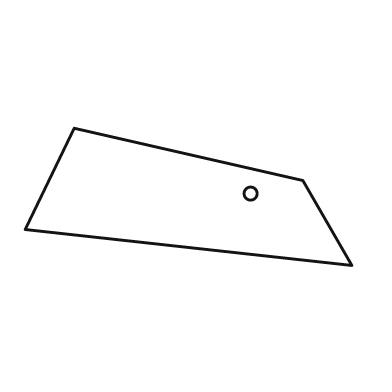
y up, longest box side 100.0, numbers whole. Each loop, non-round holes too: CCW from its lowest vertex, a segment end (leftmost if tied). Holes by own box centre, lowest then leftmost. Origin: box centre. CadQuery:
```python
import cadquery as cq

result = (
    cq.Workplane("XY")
    .moveTo(50.0, -21.0)
    .lineTo(35.0, 5.0)
    .lineTo(-35.0, 21.0)
    .lineTo(-50.0, -10.0)
    .close()
    .moveTo(19.0, 1.0)
    .circle(2.0)
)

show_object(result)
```